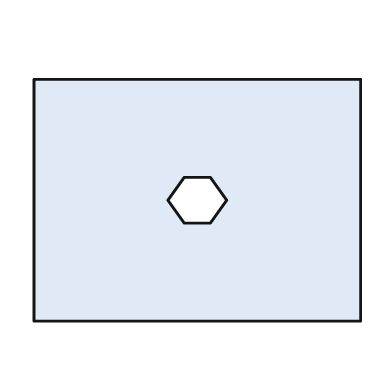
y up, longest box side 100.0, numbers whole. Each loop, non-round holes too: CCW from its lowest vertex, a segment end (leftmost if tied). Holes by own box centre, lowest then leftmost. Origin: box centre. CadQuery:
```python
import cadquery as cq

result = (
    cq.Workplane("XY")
    .moveTo(-50.0, -37.0)
    .lineTo(50.0, -37.0)
    .lineTo(50.0, 37.0)
    .lineTo(-50.0, 37.0)
    .close()
    .moveTo(-4.0, -7.0)
    .lineTo(4.0, -7.0)
    .lineTo(9.0, 0.0)
    .lineTo(4.0, 7.0)
    .lineTo(-4.0, 7.0)
    .lineTo(-9.0, 0.0)
    .close()
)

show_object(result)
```